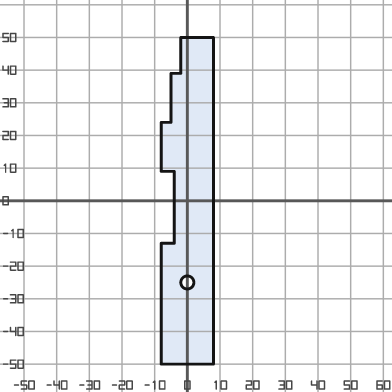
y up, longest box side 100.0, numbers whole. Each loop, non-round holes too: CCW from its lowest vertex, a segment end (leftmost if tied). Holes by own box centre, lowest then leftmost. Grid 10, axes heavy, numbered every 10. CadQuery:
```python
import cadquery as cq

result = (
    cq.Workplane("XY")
    .moveTo(-8.0, -50.0)
    .lineTo(8.0, -50.0)
    .lineTo(8.0, 50.0)
    .lineTo(-2.0, 50.0)
    .lineTo(-2.0, 39.0)
    .lineTo(-5.0, 39.0)
    .lineTo(-5.0, 24.0)
    .lineTo(-8.0, 24.0)
    .lineTo(-8.0, 9.0)
    .lineTo(-4.0, 9.0)
    .lineTo(-4.0, -13.0)
    .lineTo(-8.0, -13.0)
    .close()
    .moveTo(0.0, -25.0)
    .circle(2.0)
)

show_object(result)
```